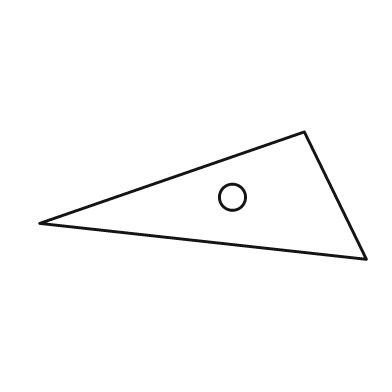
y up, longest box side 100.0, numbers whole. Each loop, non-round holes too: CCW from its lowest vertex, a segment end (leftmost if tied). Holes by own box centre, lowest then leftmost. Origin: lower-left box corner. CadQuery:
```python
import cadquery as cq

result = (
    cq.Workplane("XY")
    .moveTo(100.0, 0.0)
    .lineTo(81.0, 39.0)
    .lineTo(0.0, 11.0)
    .close()
    .moveTo(59.0, 19.0)
    .circle(4.0)
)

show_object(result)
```